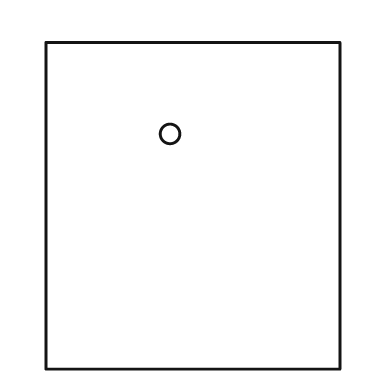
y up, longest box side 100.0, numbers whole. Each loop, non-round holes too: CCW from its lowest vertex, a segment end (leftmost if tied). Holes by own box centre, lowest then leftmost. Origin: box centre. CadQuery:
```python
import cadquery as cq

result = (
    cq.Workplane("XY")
    .moveTo(-45.0, -50.0)
    .lineTo(45.0, -50.0)
    .lineTo(45.0, 50.0)
    .lineTo(-45.0, 50.0)
    .close()
    .moveTo(-7.0, 22.0)
    .circle(3.0)
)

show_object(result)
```